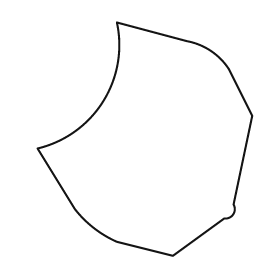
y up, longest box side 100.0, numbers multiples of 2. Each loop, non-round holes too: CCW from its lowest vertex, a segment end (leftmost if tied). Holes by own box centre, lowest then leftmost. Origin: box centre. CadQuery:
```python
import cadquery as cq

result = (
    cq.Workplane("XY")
    .moveTo(12.0, -50.0)
    .lineTo(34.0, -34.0)
    .threePointArc((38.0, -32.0), (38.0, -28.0))
    .lineTo(46.0, 10.0)
    .lineTo(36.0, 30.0)
    .threePointArc((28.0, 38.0), (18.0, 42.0))
    .lineTo(-12.0, 50.0)
    .threePointArc((-18.0, 16.0), (-46.0, -4.0))
    .lineTo(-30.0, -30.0)
    .threePointArc((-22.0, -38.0), (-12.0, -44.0))
    .close()
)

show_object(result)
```